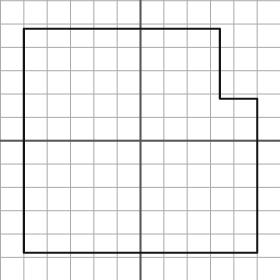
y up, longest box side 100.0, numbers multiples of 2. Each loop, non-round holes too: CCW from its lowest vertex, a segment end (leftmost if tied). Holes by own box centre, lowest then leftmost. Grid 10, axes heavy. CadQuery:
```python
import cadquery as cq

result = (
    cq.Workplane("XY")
    .moveTo(-50.0, -48.0)
    .lineTo(50.0, -48.0)
    .lineTo(50.0, 18.0)
    .lineTo(34.0, 18.0)
    .lineTo(34.0, 48.0)
    .lineTo(-50.0, 48.0)
    .close()
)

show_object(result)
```